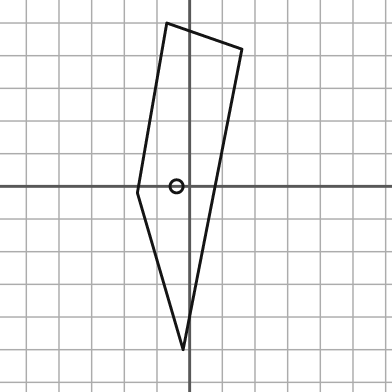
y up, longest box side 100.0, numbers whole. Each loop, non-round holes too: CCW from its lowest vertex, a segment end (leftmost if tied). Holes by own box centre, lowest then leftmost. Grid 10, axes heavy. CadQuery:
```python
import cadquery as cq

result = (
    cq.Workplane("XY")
    .moveTo(-2.0, -50.0)
    .lineTo(16.0, 42.0)
    .lineTo(-7.0, 50.0)
    .lineTo(-16.0, -2.0)
    .close()
    .moveTo(-4.0, 0.0)
    .circle(2.0)
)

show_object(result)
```